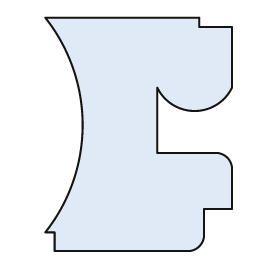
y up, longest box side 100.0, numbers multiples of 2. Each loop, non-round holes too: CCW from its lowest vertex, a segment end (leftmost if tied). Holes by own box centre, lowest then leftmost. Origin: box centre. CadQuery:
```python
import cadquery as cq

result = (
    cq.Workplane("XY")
    .moveTo(-36.0, -50.0)
    .lineTo(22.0, -50.0)
    .threePointArc((26.0, -48.0), (28.0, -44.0))
    .lineTo(28.0, -32.0)
    .lineTo(40.0, -32.0)
    .lineTo(40.0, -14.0)
    .threePointArc((38.0, -10.0), (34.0, -8.0))
    .lineTo(8.0, -8.0)
    .lineTo(8.0, 20.0)
    .threePointArc((24.0, 10.0), (40.0, 20.0))
    .lineTo(40.0, 46.0)
    .lineTo(26.0, 46.0)
    .lineTo(26.0, 50.0)
    .lineTo(-40.0, 50.0)
    .threePointArc((-24.0, 4.0), (-40.0, -42.0))
    .lineTo(-36.0, -42.0)
    .close()
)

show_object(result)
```